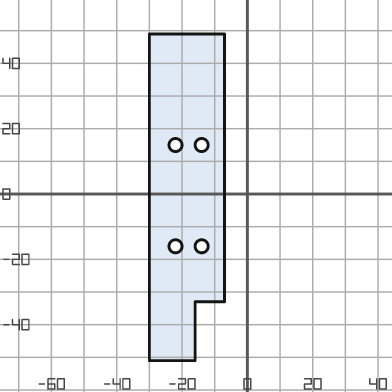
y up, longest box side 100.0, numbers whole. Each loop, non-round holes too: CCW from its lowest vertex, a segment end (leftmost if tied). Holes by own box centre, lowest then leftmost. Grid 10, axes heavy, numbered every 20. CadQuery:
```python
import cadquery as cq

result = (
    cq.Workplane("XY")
    .moveTo(-30.0, -51.0)
    .lineTo(-16.0, -51.0)
    .lineTo(-16.0, -33.0)
    .lineTo(-7.0, -33.0)
    .lineTo(-7.0, 49.0)
    .lineTo(-30.0, 49.0)
    .close()
    .moveTo(-22.0, -16.0)
    .circle(2.0)
    .moveTo(-14.0, -16.0)
    .circle(2.0)
    .moveTo(-22.0, 15.0)
    .circle(2.0)
    .moveTo(-14.0, 15.0)
    .circle(2.0)
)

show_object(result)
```